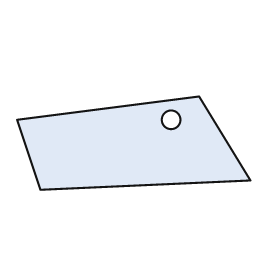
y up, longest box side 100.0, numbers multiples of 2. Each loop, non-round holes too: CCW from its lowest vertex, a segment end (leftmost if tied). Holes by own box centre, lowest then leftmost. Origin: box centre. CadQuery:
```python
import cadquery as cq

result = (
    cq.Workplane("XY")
    .moveTo(-40.0, -20.0)
    .lineTo(50.0, -16.0)
    .lineTo(28.0, 20.0)
    .lineTo(-50.0, 10.0)
    .close()
    .moveTo(16.0, 10.0)
    .circle(4.0)
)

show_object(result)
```